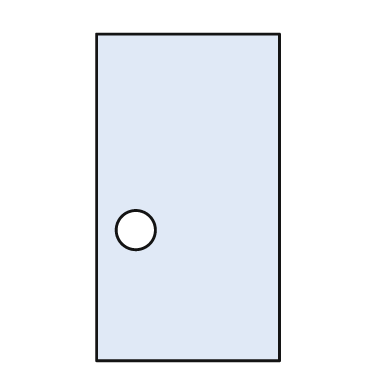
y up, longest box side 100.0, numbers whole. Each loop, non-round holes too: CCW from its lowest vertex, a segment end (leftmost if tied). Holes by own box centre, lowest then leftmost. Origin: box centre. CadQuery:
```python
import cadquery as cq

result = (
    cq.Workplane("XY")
    .moveTo(-28.0, -50.0)
    .lineTo(28.0, -50.0)
    .lineTo(28.0, 50.0)
    .lineTo(-28.0, 50.0)
    .close()
    .moveTo(-16.0, -10.0)
    .circle(6.0)
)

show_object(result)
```